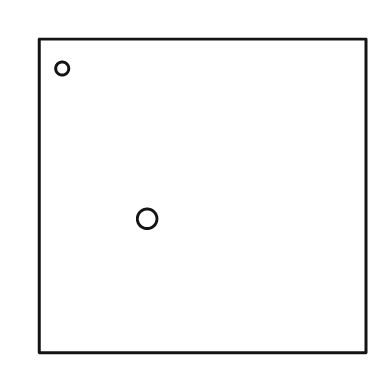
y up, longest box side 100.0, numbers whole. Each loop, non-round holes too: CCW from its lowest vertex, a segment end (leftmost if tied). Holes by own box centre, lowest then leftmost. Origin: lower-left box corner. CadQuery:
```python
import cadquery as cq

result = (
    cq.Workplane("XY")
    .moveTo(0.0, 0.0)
    .lineTo(100.0, 0.0)
    .lineTo(100.0, 96.0)
    .lineTo(0.0, 96.0)
    .close()
    .moveTo(33.0, 41.0)
    .circle(3.0)
    .moveTo(7.0, 87.0)
    .circle(2.0)
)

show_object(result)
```